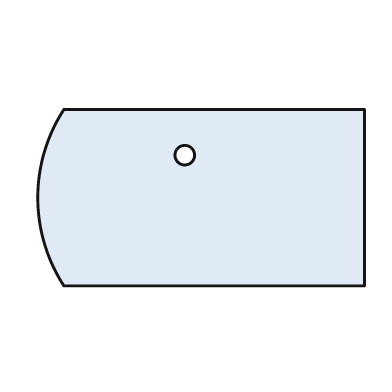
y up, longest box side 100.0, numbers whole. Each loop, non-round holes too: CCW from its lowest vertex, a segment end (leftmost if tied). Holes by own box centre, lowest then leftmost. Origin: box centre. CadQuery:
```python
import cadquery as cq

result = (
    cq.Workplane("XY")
    .moveTo(-42.0, -27.0)
    .lineTo(50.0, -27.0)
    .lineTo(50.0, 27.0)
    .lineTo(-42.0, 27.0)
    .threePointArc((-50.0, 0.0), (-42.0, -27.0))
    .close()
    .moveTo(-5.0, 13.0)
    .circle(3.0)
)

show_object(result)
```